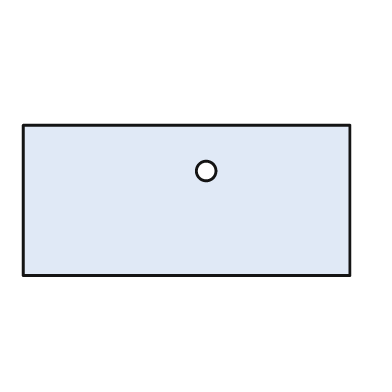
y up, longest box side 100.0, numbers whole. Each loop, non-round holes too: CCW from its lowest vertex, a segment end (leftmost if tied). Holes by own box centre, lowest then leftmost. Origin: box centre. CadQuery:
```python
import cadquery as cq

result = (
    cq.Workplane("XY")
    .moveTo(-50.0, -23.0)
    .lineTo(50.0, -23.0)
    .lineTo(50.0, 23.0)
    .lineTo(-50.0, 23.0)
    .close()
    .moveTo(6.0, 9.0)
    .circle(3.0)
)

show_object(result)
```